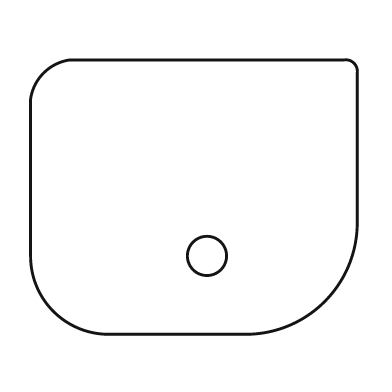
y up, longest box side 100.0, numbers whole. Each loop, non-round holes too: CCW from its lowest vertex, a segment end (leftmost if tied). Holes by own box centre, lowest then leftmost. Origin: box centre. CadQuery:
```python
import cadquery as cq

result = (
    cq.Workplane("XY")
    .moveTo(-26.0, -42.0)
    .lineTo(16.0, -42.0)
    .threePointArc((40.0, -32.0), (50.0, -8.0))
    .lineTo(50.0, 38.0)
    .threePointArc((49.0, 41.0), (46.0, 42.0))
    .lineTo(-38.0, 42.0)
    .threePointArc((-46.0, 38.0), (-50.0, 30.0))
    .lineTo(-50.0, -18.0)
    .threePointArc((-43.0, -35.0), (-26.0, -42.0))
    .close()
    .moveTo(4.0, -18.0)
    .circle(6.0)
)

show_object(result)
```